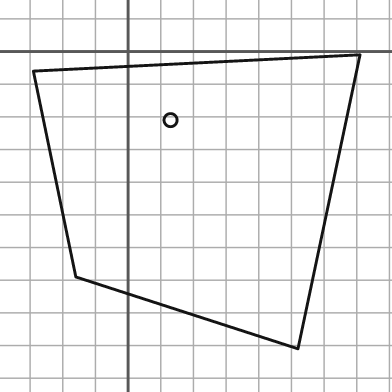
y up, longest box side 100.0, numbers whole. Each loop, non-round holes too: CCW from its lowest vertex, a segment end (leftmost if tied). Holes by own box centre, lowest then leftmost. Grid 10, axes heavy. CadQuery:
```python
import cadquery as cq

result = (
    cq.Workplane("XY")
    .moveTo(52.0, -91.0)
    .lineTo(71.0, -1.0)
    .lineTo(-29.0, -6.0)
    .lineTo(-16.0, -69.0)
    .close()
    .moveTo(13.0, -21.0)
    .circle(2.0)
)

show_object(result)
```